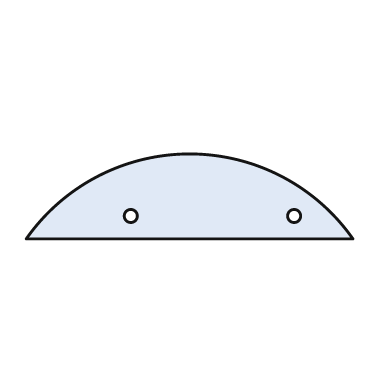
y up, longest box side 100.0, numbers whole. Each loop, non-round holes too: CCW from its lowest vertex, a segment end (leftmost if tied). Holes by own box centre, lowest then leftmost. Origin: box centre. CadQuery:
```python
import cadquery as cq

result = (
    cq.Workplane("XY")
    .moveTo(-50.0, -13.0)
    .lineTo(50.0, -13.0)
    .threePointArc((0.0, 13.0), (-50.0, -13.0))
    .close()
    .moveTo(-18.0, -6.0)
    .circle(2.0)
    .moveTo(32.0, -6.0)
    .circle(2.0)
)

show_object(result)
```